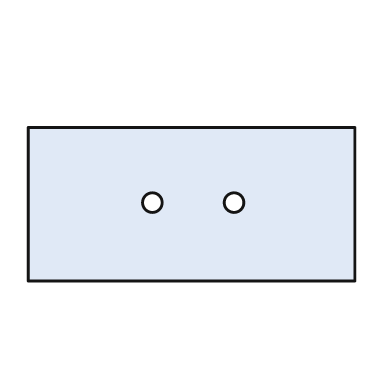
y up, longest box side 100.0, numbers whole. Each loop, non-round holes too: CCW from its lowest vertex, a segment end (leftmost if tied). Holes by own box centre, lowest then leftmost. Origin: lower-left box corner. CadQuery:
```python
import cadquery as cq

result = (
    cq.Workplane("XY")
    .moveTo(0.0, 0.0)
    .lineTo(100.0, 0.0)
    .lineTo(100.0, 47.0)
    .lineTo(0.0, 47.0)
    .close()
    .moveTo(38.0, 24.0)
    .circle(3.0)
    .moveTo(63.0, 24.0)
    .circle(3.0)
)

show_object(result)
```